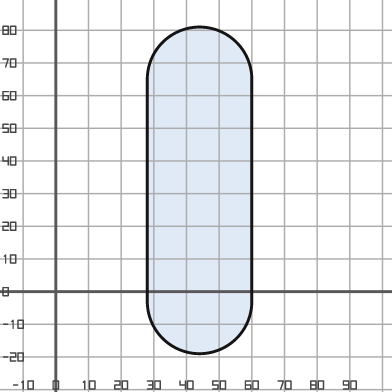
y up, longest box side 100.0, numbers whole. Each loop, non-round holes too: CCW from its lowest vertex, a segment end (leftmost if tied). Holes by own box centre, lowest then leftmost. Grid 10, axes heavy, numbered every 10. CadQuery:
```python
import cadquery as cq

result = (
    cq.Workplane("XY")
    .moveTo(28.0, -3.0)
    .threePointArc((44.0, -19.0), (60.0, -3.0))
    .lineTo(60.0, 65.0)
    .threePointArc((44.0, 81.0), (28.0, 65.0))
    .close()
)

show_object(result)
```